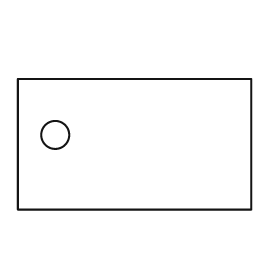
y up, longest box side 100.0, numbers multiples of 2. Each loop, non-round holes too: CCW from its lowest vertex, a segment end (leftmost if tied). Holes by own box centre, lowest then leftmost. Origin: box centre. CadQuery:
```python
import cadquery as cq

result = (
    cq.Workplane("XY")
    .moveTo(-50.0, -28.0)
    .lineTo(50.0, -28.0)
    .lineTo(50.0, 28.0)
    .lineTo(-50.0, 28.0)
    .close()
    .moveTo(-34.0, 4.0)
    .circle(6.0)
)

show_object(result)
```